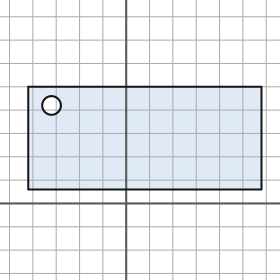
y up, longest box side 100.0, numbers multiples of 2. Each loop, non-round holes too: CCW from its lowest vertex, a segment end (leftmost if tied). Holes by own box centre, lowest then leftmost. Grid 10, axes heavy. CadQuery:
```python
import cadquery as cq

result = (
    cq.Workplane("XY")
    .moveTo(-42.0, 6.0)
    .lineTo(58.0, 6.0)
    .lineTo(58.0, 50.0)
    .lineTo(-42.0, 50.0)
    .close()
    .moveTo(-32.0, 42.0)
    .circle(4.0)
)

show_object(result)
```